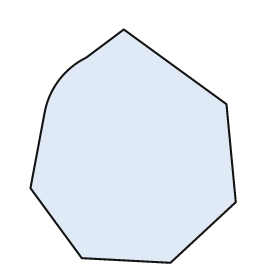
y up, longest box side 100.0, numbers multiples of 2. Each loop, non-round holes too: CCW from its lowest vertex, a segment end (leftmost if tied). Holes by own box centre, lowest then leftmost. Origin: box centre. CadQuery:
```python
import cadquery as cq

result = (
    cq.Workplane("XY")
    .moveTo(16.0, -50.0)
    .lineTo(44.0, -24.0)
    .lineTo(40.0, 18.0)
    .lineTo(-4.0, 50.0)
    .lineTo(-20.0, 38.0)
    .threePointArc((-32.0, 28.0), (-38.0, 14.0))
    .lineTo(-44.0, -18.0)
    .lineTo(-22.0, -48.0)
    .close()
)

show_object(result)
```